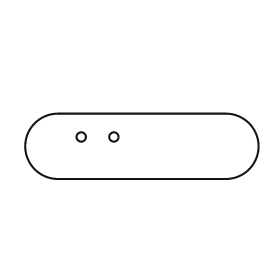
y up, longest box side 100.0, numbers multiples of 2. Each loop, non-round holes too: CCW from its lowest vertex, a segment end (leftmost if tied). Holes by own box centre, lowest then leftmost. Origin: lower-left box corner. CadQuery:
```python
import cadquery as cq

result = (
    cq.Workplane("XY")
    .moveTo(14.0, 0.0)
    .lineTo(86.0, 0.0)
    .threePointArc((100.0, 14.0), (86.0, 28.0))
    .lineTo(14.0, 28.0)
    .threePointArc((0.0, 14.0), (14.0, 0.0))
    .close()
    .moveTo(24.0, 18.0)
    .circle(2.0)
    .moveTo(38.0, 18.0)
    .circle(2.0)
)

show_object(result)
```